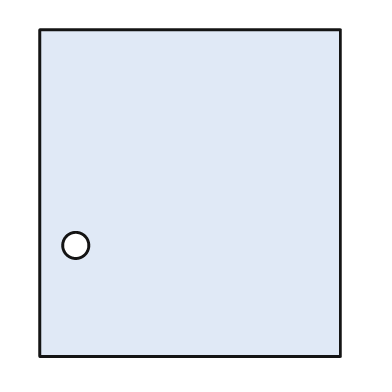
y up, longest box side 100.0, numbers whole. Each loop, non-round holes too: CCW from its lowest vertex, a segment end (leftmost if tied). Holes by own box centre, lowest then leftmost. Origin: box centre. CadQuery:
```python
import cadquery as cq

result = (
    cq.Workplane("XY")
    .moveTo(-46.0, -50.0)
    .lineTo(46.0, -50.0)
    .lineTo(46.0, 50.0)
    .lineTo(-46.0, 50.0)
    .close()
    .moveTo(-35.0, -16.0)
    .circle(4.0)
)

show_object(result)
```